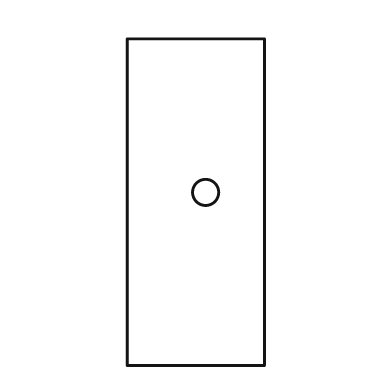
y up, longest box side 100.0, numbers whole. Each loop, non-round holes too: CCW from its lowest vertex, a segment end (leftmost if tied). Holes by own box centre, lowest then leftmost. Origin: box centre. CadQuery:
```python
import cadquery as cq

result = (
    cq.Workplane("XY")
    .moveTo(-21.0, -50.0)
    .lineTo(21.0, -50.0)
    .lineTo(21.0, 50.0)
    .lineTo(-21.0, 50.0)
    .close()
    .moveTo(3.0, 3.0)
    .circle(4.0)
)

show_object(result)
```